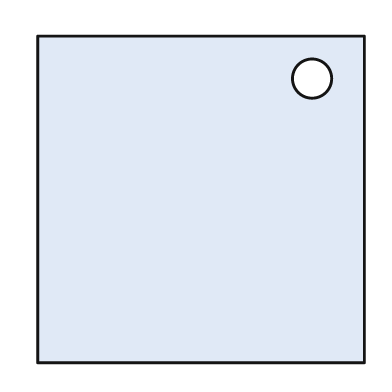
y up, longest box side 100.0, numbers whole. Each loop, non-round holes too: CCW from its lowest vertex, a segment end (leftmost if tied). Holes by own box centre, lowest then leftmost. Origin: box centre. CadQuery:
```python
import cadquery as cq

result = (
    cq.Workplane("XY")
    .moveTo(-50.0, -50.0)
    .lineTo(50.0, -50.0)
    .lineTo(50.0, 50.0)
    .lineTo(-50.0, 50.0)
    .close()
    .moveTo(34.0, 37.0)
    .circle(6.0)
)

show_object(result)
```